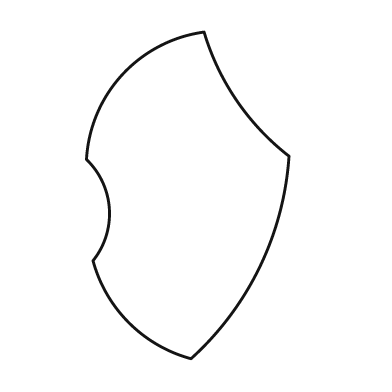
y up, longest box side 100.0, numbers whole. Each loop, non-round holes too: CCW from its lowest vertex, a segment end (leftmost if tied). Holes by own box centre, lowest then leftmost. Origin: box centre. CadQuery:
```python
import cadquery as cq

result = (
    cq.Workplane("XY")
    .moveTo(1.0, -50.0)
    .threePointArc((22.0, -22.0), (31.0, 12.0))
    .threePointArc((15.0, 29.0), (5.0, 50.0))
    .threePointArc((-20.0, 37.0), (-31.0, 11.0))
    .threePointArc((-24.0, -4.0), (-29.0, -20.0))
    .threePointArc((-18.0, -39.0), (1.0, -50.0))
    .close()
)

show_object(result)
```